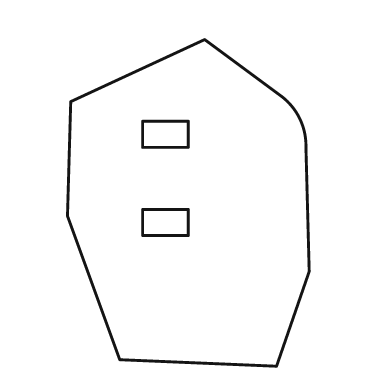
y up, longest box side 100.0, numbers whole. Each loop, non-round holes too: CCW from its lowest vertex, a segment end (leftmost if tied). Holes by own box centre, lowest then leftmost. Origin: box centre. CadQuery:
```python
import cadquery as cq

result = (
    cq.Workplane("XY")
    .moveTo(27.0, -50.0)
    .lineTo(37.0, -21.0)
    .lineTo(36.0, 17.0)
    .threePointArc((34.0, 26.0), (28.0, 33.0))
    .lineTo(5.0, 50.0)
    .lineTo(-36.0, 31.0)
    .lineTo(-37.0, -4.0)
    .lineTo(-21.0, -48.0)
    .close()
    .moveTo(-14.0, -10.0)
    .lineTo(0.0, -10.0)
    .lineTo(0.0, -2.0)
    .lineTo(-14.0, -2.0)
    .close()
    .moveTo(-14.0, 17.0)
    .lineTo(0.0, 17.0)
    .lineTo(0.0, 25.0)
    .lineTo(-14.0, 25.0)
    .close()
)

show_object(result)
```